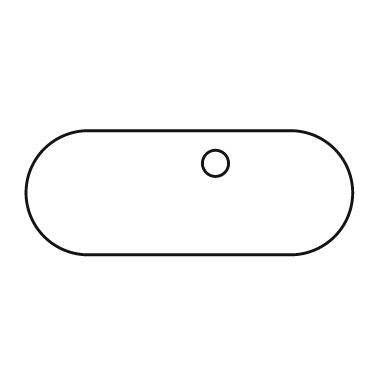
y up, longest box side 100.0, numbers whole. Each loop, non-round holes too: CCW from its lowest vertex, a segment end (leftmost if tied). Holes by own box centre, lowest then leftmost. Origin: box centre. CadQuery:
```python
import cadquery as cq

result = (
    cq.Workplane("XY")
    .moveTo(-31.0, -19.0)
    .lineTo(31.0, -19.0)
    .threePointArc((50.0, 0.0), (31.0, 19.0))
    .lineTo(-31.0, 19.0)
    .threePointArc((-50.0, 0.0), (-31.0, -19.0))
    .close()
    .moveTo(8.0, 9.0)
    .circle(4.0)
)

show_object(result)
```